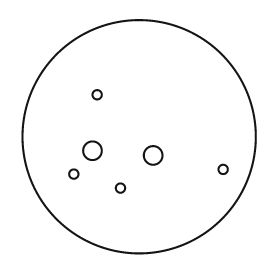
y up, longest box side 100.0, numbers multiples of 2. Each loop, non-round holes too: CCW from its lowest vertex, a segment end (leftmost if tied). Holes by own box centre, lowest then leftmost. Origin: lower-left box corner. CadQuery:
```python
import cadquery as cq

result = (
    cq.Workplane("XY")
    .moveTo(50.0, 50.0)
    .circle(50.0)
    .moveTo(42.0, 28.0)
    .circle(2.0)
    .moveTo(22.0, 34.0)
    .circle(2.0)
    .moveTo(86.0, 36.0)
    .circle(2.0)
    .moveTo(56.0, 42.0)
    .circle(4.0)
    .moveTo(30.0, 44.0)
    .circle(4.0)
    .moveTo(32.0, 68.0)
    .circle(2.0)
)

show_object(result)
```